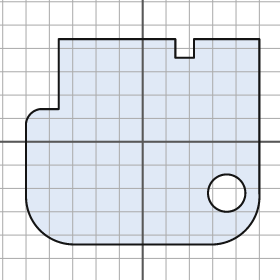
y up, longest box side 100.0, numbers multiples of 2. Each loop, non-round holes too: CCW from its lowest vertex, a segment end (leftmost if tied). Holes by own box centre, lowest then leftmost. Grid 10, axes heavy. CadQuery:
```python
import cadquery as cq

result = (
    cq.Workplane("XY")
    .moveTo(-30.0, -44.0)
    .lineTo(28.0, -44.0)
    .threePointArc((44.0, -38.0), (50.0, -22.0))
    .lineTo(50.0, 44.0)
    .lineTo(22.0, 44.0)
    .lineTo(22.0, 36.0)
    .lineTo(14.0, 36.0)
    .lineTo(14.0, 44.0)
    .lineTo(-36.0, 44.0)
    .lineTo(-36.0, 14.0)
    .lineTo(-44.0, 14.0)
    .threePointArc((-48.0, 12.0), (-50.0, 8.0))
    .lineTo(-50.0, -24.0)
    .threePointArc((-44.0, -38.0), (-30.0, -44.0))
    .close()
    .moveTo(36.0, -22.0)
    .circle(8.0)
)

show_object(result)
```